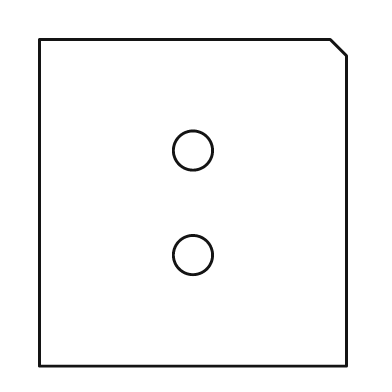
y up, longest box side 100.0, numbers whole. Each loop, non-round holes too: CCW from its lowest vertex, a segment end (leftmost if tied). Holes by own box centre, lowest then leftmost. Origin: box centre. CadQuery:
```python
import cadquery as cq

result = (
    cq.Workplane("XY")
    .moveTo(-47.0, -50.0)
    .lineTo(47.0, -50.0)
    .lineTo(47.0, 45.0)
    .lineTo(42.0, 50.0)
    .lineTo(-47.0, 50.0)
    .close()
    .moveTo(0.0, -16.0)
    .circle(6.0)
    .moveTo(0.0, 16.0)
    .circle(6.0)
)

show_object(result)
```